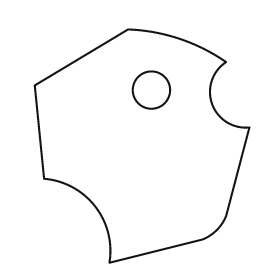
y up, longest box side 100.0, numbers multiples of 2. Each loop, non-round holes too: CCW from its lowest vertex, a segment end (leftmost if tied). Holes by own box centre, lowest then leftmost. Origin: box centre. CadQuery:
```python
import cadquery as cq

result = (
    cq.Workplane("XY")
    .moveTo(-14.0, -50.0)
    .lineTo(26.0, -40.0)
    .threePointArc((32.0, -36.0), (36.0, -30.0))
    .lineTo(46.0, 8.0)
    .threePointArc((30.0, 18.0), (36.0, 36.0))
    .threePointArc((16.0, 46.0), (-6.0, 50.0))
    .lineTo(-46.0, 26.0)
    .lineTo(-42.0, -14.0)
    .threePointArc((-20.0, -26.0), (-14.0, -50.0))
    .close()
    .moveTo(4.0, 24.0)
    .circle(8.0)
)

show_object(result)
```